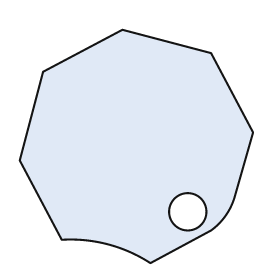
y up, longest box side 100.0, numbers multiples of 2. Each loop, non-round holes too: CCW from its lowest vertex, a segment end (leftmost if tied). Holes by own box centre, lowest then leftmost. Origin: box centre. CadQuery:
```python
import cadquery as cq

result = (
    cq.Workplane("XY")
    .moveTo(6.0, -50.0)
    .lineTo(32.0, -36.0)
    .threePointArc((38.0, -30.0), (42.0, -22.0))
    .lineTo(50.0, 6.0)
    .lineTo(32.0, 40.0)
    .lineTo(-6.0, 50.0)
    .lineTo(-40.0, 32.0)
    .lineTo(-50.0, -6.0)
    .lineTo(-32.0, -40.0)
    .threePointArc((-12.0, -42.0), (6.0, -50.0))
    .close()
    .moveTo(22.0, -28.0)
    .circle(8.0)
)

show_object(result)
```